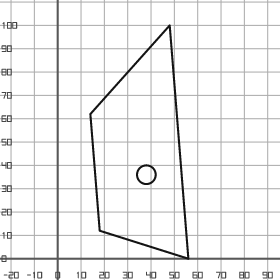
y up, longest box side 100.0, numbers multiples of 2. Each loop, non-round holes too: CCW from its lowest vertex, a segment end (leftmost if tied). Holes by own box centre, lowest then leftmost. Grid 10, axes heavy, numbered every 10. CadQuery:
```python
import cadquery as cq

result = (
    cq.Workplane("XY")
    .moveTo(56.0, 0.0)
    .lineTo(48.0, 100.0)
    .lineTo(14.0, 62.0)
    .lineTo(18.0, 12.0)
    .close()
    .moveTo(38.0, 36.0)
    .circle(4.0)
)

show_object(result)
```